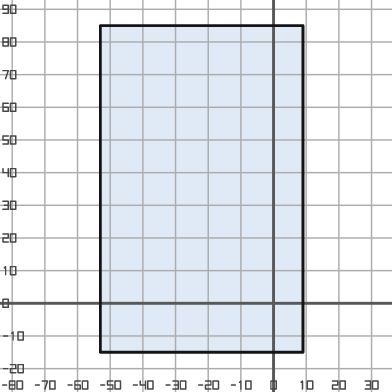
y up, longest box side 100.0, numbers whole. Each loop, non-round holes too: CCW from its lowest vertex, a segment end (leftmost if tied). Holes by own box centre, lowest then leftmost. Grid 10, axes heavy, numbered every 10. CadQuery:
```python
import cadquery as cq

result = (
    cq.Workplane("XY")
    .moveTo(-53.0, -15.0)
    .lineTo(9.0, -15.0)
    .lineTo(9.0, 85.0)
    .lineTo(-53.0, 85.0)
    .close()
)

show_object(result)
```